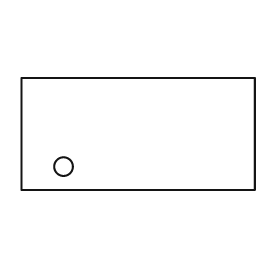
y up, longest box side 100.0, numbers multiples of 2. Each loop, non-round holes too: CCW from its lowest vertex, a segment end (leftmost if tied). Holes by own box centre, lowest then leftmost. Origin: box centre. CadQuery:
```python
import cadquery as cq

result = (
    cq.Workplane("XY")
    .moveTo(-50.0, -24.0)
    .lineTo(50.0, -24.0)
    .lineTo(50.0, 24.0)
    .lineTo(-50.0, 24.0)
    .close()
    .moveTo(-32.0, -14.0)
    .circle(4.0)
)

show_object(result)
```